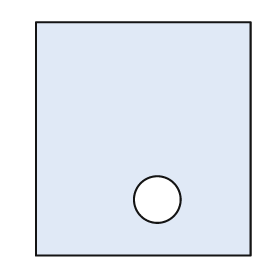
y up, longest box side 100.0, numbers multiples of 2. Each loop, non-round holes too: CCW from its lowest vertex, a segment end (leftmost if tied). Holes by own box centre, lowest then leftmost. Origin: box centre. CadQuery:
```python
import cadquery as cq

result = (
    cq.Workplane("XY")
    .moveTo(-46.0, -50.0)
    .lineTo(46.0, -50.0)
    .lineTo(46.0, 50.0)
    .lineTo(-46.0, 50.0)
    .close()
    .moveTo(6.0, -26.0)
    .circle(10.0)
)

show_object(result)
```